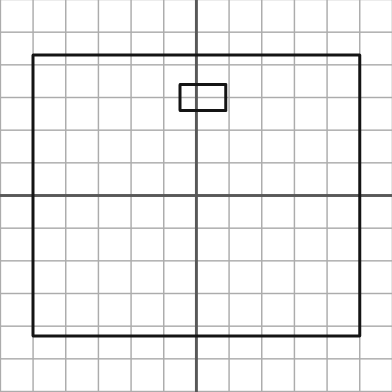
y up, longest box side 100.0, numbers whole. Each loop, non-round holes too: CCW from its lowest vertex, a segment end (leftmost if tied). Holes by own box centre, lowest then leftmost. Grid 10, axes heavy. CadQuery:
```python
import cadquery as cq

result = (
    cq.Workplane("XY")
    .moveTo(-50.0, -43.0)
    .lineTo(50.0, -43.0)
    .lineTo(50.0, 43.0)
    .lineTo(-50.0, 43.0)
    .close()
    .moveTo(-5.0, 26.0)
    .lineTo(9.0, 26.0)
    .lineTo(9.0, 34.0)
    .lineTo(-5.0, 34.0)
    .close()
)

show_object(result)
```